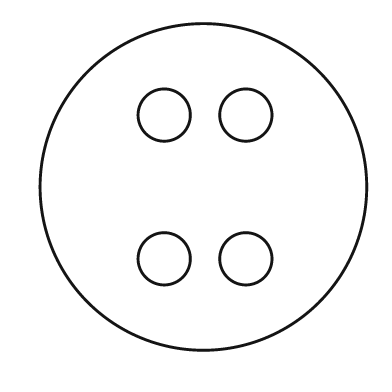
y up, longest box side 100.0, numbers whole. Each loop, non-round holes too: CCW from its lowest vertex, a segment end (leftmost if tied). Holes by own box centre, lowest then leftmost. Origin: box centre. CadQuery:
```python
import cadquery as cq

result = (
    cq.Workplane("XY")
    .moveTo(0.0, 0.0)
    .circle(50.0)
    .moveTo(-12.0, -22.0)
    .circle(8.0)
    .moveTo(13.0, -22.0)
    .circle(8.0)
    .moveTo(-12.0, 22.0)
    .circle(8.0)
    .moveTo(13.0, 22.0)
    .circle(8.0)
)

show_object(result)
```